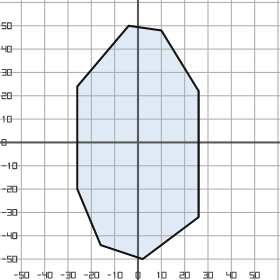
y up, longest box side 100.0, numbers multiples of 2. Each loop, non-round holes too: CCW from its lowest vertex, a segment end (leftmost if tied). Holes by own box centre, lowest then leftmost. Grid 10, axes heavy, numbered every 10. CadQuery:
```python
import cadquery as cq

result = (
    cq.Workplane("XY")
    .moveTo(2.0, -50.0)
    .lineTo(26.0, -32.0)
    .lineTo(26.0, 22.0)
    .lineTo(10.0, 48.0)
    .lineTo(-4.0, 50.0)
    .lineTo(-26.0, 24.0)
    .lineTo(-26.0, -20.0)
    .lineTo(-16.0, -44.0)
    .close()
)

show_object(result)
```